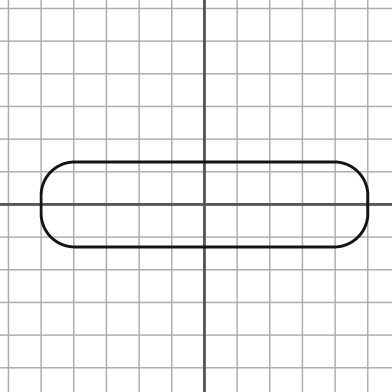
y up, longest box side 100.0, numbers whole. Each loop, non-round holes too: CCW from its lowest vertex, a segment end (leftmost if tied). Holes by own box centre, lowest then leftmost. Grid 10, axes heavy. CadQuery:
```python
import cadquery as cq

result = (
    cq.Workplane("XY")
    .moveTo(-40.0, -13.0)
    .lineTo(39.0, -13.0)
    .threePointArc((47.0, -10.0), (50.0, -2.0))
    .lineTo(50.0, 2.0)
    .threePointArc((47.0, 10.0), (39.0, 13.0))
    .lineTo(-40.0, 13.0)
    .threePointArc((-47.0, 10.0), (-50.0, 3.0))
    .lineTo(-50.0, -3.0)
    .threePointArc((-47.0, -10.0), (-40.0, -13.0))
    .close()
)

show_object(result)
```